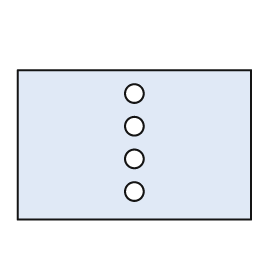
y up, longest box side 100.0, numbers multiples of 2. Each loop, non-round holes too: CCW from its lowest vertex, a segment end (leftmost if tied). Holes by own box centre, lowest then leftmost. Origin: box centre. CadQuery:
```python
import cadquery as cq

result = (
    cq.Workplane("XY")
    .moveTo(-50.0, -32.0)
    .lineTo(50.0, -32.0)
    .lineTo(50.0, 32.0)
    .lineTo(-50.0, 32.0)
    .close()
    .moveTo(0.0, -20.0)
    .circle(4.0)
    .moveTo(0.0, -6.0)
    .circle(4.0)
    .moveTo(0.0, 8.0)
    .circle(4.0)
    .moveTo(0.0, 22.0)
    .circle(4.0)
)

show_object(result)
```